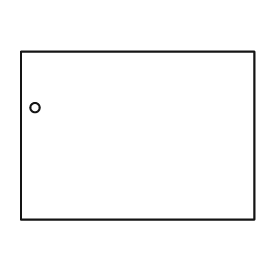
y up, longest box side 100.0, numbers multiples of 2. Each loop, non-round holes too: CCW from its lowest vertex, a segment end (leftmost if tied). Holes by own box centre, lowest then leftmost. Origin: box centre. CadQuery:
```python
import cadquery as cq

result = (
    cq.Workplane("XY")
    .moveTo(-50.0, -36.0)
    .lineTo(50.0, -36.0)
    .lineTo(50.0, 36.0)
    .lineTo(-50.0, 36.0)
    .close()
    .moveTo(-44.0, 12.0)
    .circle(2.0)
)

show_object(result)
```